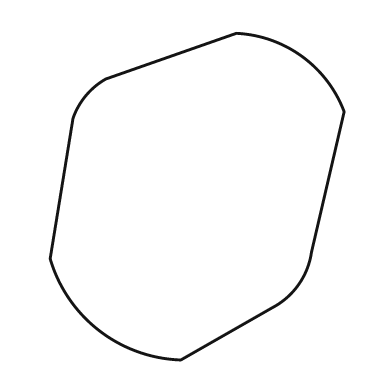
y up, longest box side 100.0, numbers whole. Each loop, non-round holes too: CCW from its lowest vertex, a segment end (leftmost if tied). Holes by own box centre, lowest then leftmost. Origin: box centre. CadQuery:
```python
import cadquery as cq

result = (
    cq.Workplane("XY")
    .moveTo(-5.0, -50.0)
    .lineTo(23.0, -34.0)
    .threePointArc((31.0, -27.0), (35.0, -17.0))
    .lineTo(45.0, 26.0)
    .threePointArc((32.0, 43.0), (12.0, 50.0))
    .lineTo(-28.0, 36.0)
    .threePointArc((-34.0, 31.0), (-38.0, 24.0))
    .lineTo(-45.0, -19.0)
    .threePointArc((-30.0, -41.0), (-5.0, -50.0))
    .close()
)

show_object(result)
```